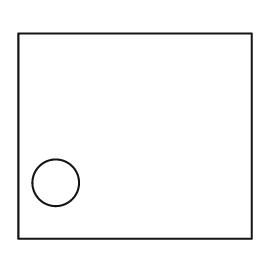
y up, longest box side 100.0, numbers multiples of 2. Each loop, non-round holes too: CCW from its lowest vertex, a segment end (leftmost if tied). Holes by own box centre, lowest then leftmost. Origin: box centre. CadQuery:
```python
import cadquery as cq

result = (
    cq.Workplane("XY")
    .moveTo(-50.0, -44.0)
    .lineTo(50.0, -44.0)
    .lineTo(50.0, 44.0)
    .lineTo(-50.0, 44.0)
    .close()
    .moveTo(-34.0, -20.0)
    .circle(10.0)
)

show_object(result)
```